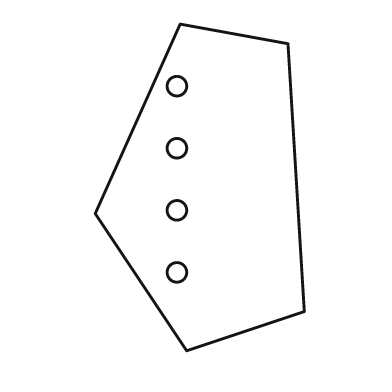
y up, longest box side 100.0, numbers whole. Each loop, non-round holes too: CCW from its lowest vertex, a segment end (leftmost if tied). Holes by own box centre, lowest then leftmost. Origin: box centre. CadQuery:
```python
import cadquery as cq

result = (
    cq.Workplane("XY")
    .moveTo(-4.0, -50.0)
    .lineTo(32.0, -38.0)
    .lineTo(27.0, 44.0)
    .lineTo(-6.0, 50.0)
    .lineTo(-32.0, -8.0)
    .close()
    .moveTo(-7.0, -26.0)
    .circle(3.0)
    .moveTo(-7.0, -7.0)
    .circle(3.0)
    .moveTo(-7.0, 12.0)
    .circle(3.0)
    .moveTo(-7.0, 31.0)
    .circle(3.0)
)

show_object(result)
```